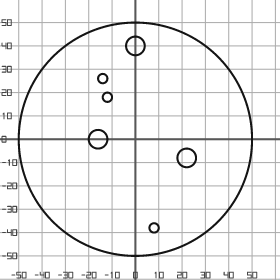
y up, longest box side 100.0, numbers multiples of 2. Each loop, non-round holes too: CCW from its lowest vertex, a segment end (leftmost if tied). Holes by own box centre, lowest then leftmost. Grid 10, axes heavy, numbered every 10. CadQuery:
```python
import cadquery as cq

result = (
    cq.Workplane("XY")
    .moveTo(0.0, 0.0)
    .circle(50.0)
    .moveTo(8.0, -38.0)
    .circle(2.0)
    .moveTo(22.0, -8.0)
    .circle(4.0)
    .moveTo(-16.0, 0.0)
    .circle(4.0)
    .moveTo(-12.0, 18.0)
    .circle(2.0)
    .moveTo(-14.0, 26.0)
    .circle(2.0)
    .moveTo(0.0, 40.0)
    .circle(4.0)
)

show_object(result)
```